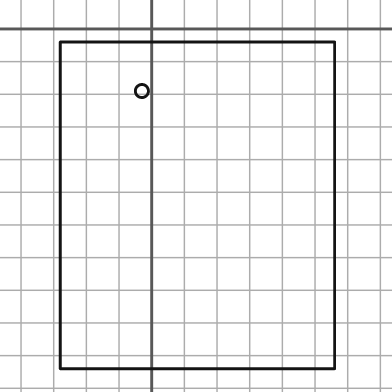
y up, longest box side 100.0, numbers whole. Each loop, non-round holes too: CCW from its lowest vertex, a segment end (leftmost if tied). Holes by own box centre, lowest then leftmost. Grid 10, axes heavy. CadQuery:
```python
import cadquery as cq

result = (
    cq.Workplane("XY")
    .moveTo(-28.0, -104.0)
    .lineTo(56.0, -104.0)
    .lineTo(56.0, -4.0)
    .lineTo(-28.0, -4.0)
    .close()
    .moveTo(-3.0, -19.0)
    .circle(2.0)
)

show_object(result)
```